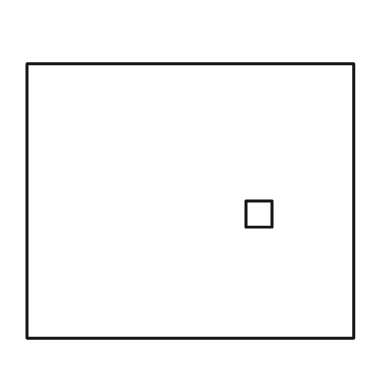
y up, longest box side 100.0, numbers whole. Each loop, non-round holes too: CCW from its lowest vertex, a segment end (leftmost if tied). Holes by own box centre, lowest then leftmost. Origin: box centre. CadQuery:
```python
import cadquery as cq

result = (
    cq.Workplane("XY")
    .moveTo(-50.0, -42.0)
    .lineTo(50.0, -42.0)
    .lineTo(50.0, 42.0)
    .lineTo(-50.0, 42.0)
    .close()
    .moveTo(17.0, -8.0)
    .lineTo(25.0, -8.0)
    .lineTo(25.0, 0.0)
    .lineTo(17.0, 0.0)
    .close()
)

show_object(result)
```